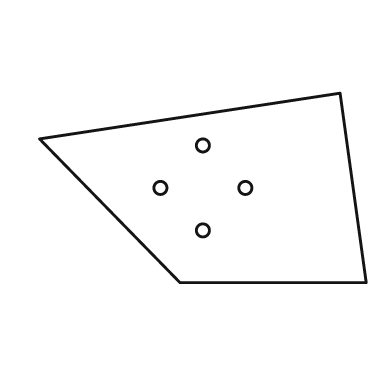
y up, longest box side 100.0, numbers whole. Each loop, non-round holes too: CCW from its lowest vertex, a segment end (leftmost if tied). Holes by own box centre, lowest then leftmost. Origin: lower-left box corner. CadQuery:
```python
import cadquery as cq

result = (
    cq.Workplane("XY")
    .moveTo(43.0, 0.0)
    .lineTo(100.0, 0.0)
    .lineTo(92.0, 58.0)
    .lineTo(0.0, 44.0)
    .close()
    .moveTo(50.0, 16.0)
    .circle(2.0)
    .moveTo(37.0, 29.0)
    .circle(2.0)
    .moveTo(63.0, 29.0)
    .circle(2.0)
    .moveTo(50.0, 42.0)
    .circle(2.0)
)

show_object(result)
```